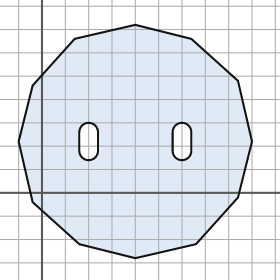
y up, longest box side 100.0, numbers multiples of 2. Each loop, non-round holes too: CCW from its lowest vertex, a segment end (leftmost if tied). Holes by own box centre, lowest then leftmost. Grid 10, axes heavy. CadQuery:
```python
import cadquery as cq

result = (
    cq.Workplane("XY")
    .moveTo(40.0, -28.0)
    .lineTo(66.0, -22.0)
    .lineTo(84.0, -2.0)
    .lineTo(90.0, 22.0)
    .lineTo(84.0, 48.0)
    .lineTo(64.0, 66.0)
    .lineTo(40.0, 72.0)
    .lineTo(14.0, 66.0)
    .lineTo(-4.0, 46.0)
    .lineTo(-10.0, 22.0)
    .lineTo(-4.0, -4.0)
    .lineTo(16.0, -22.0)
    .close()
    .moveTo(16.0, 18.0)
    .threePointArc((20.0, 14.0), (24.0, 18.0))
    .lineTo(24.0, 26.0)
    .threePointArc((20.0, 30.0), (16.0, 26.0))
    .close()
    .moveTo(56.0, 18.0)
    .threePointArc((60.0, 14.0), (64.0, 18.0))
    .lineTo(64.0, 26.0)
    .threePointArc((60.0, 30.0), (56.0, 26.0))
    .close()
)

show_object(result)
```